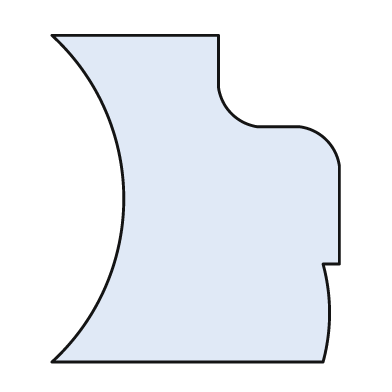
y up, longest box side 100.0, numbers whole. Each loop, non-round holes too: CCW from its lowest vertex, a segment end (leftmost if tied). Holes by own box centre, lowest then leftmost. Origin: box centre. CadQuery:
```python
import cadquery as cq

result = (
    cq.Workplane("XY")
    .moveTo(-44.0, -50.0)
    .lineTo(39.0, -50.0)
    .threePointArc((41.0, -35.0), (39.0, -20.0))
    .lineTo(44.0, -20.0)
    .lineTo(44.0, 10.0)
    .threePointArc((40.0, 18.0), (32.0, 22.0))
    .lineTo(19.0, 22.0)
    .threePointArc((11.0, 26.0), (7.0, 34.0))
    .lineTo(7.0, 50.0)
    .lineTo(-44.0, 50.0)
    .threePointArc((-22.0, 0.0), (-44.0, -50.0))
    .close()
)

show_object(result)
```